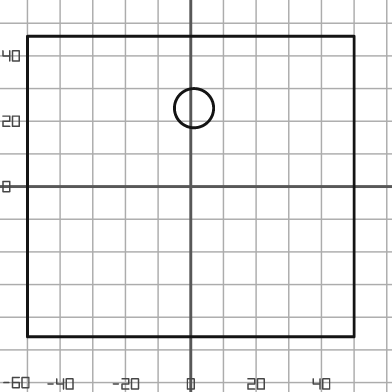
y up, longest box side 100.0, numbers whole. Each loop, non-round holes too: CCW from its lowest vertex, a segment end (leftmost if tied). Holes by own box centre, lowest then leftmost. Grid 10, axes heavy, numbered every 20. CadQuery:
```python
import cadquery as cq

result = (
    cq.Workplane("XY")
    .moveTo(-50.0, -46.0)
    .lineTo(50.0, -46.0)
    .lineTo(50.0, 46.0)
    .lineTo(-50.0, 46.0)
    .close()
    .moveTo(1.0, 24.0)
    .circle(6.0)
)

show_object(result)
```